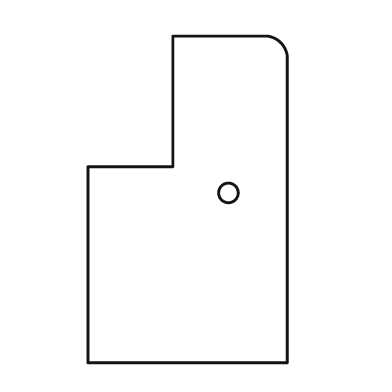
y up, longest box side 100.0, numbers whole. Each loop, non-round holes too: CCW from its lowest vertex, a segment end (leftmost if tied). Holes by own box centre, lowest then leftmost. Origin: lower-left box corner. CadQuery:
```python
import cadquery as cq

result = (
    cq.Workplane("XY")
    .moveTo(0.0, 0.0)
    .lineTo(61.0, 0.0)
    .lineTo(61.0, 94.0)
    .threePointArc((59.0, 98.0), (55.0, 100.0))
    .lineTo(26.0, 100.0)
    .lineTo(26.0, 60.0)
    .lineTo(0.0, 60.0)
    .close()
    .moveTo(43.0, 52.0)
    .circle(3.0)
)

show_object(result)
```